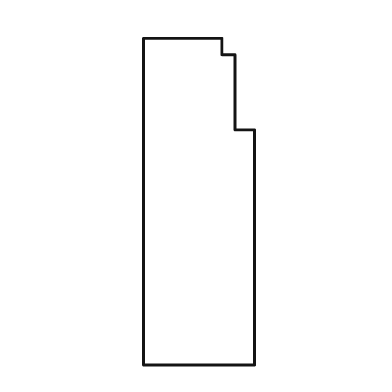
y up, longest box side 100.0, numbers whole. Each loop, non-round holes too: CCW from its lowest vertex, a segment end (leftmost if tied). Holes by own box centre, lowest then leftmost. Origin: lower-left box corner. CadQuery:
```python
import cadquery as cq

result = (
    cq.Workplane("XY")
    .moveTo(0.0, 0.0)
    .lineTo(34.0, 0.0)
    .lineTo(34.0, 72.0)
    .lineTo(28.0, 72.0)
    .lineTo(28.0, 95.0)
    .lineTo(24.0, 95.0)
    .lineTo(24.0, 100.0)
    .lineTo(0.0, 100.0)
    .close()
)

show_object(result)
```